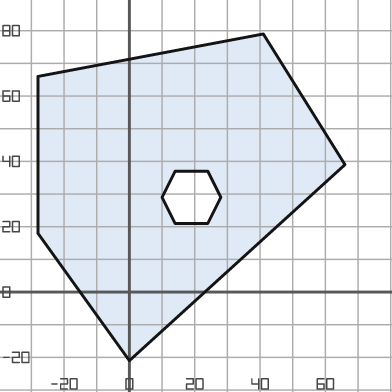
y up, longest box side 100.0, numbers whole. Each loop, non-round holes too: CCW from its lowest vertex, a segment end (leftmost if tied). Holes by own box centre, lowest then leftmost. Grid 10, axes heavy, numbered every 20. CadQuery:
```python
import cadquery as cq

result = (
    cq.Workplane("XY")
    .moveTo(0.0, -21.0)
    .lineTo(66.0, 39.0)
    .lineTo(41.0, 79.0)
    .lineTo(-28.0, 66.0)
    .lineTo(-28.0, 18.0)
    .close()
    .moveTo(14.0, 21.0)
    .lineTo(24.0, 21.0)
    .lineTo(28.0, 29.0)
    .lineTo(24.0, 37.0)
    .lineTo(14.0, 37.0)
    .lineTo(10.0, 29.0)
    .close()
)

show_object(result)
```